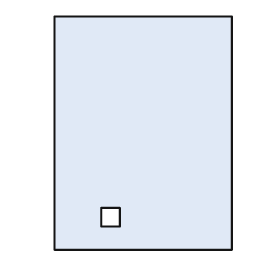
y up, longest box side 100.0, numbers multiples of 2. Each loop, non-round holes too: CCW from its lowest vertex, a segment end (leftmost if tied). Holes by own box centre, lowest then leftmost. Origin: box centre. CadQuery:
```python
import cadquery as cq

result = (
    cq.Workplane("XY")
    .moveTo(-38.0, -50.0)
    .lineTo(38.0, -50.0)
    .lineTo(38.0, 50.0)
    .lineTo(-38.0, 50.0)
    .close()
    .moveTo(-18.0, -40.0)
    .lineTo(-10.0, -40.0)
    .lineTo(-10.0, -32.0)
    .lineTo(-18.0, -32.0)
    .close()
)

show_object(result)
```